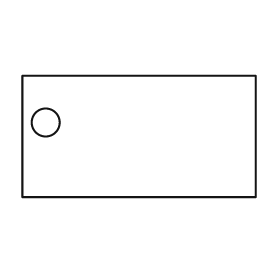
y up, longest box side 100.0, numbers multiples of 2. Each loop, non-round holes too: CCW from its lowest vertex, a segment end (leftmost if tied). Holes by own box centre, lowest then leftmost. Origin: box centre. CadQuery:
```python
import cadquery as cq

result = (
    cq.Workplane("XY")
    .moveTo(-50.0, -26.0)
    .lineTo(50.0, -26.0)
    .lineTo(50.0, 26.0)
    .lineTo(-50.0, 26.0)
    .close()
    .moveTo(-40.0, 6.0)
    .circle(6.0)
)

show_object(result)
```